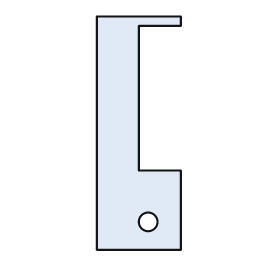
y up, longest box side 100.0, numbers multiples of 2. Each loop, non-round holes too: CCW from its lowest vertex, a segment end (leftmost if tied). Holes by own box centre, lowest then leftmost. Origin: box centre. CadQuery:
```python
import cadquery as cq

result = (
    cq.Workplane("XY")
    .moveTo(-18.0, -50.0)
    .lineTo(18.0, -50.0)
    .lineTo(18.0, -16.0)
    .lineTo(0.0, -16.0)
    .lineTo(0.0, 46.0)
    .lineTo(18.0, 46.0)
    .lineTo(18.0, 50.0)
    .lineTo(-18.0, 50.0)
    .close()
    .moveTo(4.0, -38.0)
    .circle(4.0)
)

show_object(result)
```